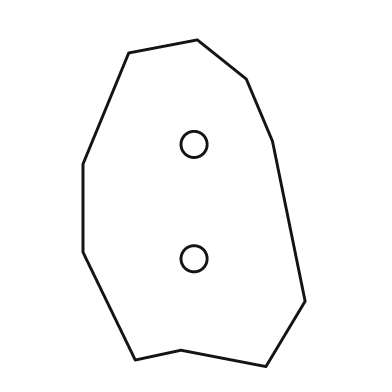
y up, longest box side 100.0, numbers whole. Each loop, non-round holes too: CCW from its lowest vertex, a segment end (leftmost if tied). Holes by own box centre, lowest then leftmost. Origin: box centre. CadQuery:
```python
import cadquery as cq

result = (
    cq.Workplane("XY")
    .moveTo(22.0, -50.0)
    .lineTo(34.0, -30.0)
    .lineTo(24.0, 19.0)
    .lineTo(16.0, 38.0)
    .lineTo(1.0, 50.0)
    .lineTo(-20.0, 46.0)
    .lineTo(-34.0, 12.0)
    .lineTo(-34.0, -15.0)
    .lineTo(-18.0, -48.0)
    .lineTo(-4.0, -45.0)
    .close()
    .moveTo(0.0, -17.0)
    .circle(4.0)
    .moveTo(0.0, 18.0)
    .circle(4.0)
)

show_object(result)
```